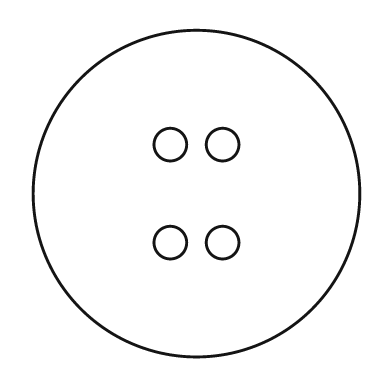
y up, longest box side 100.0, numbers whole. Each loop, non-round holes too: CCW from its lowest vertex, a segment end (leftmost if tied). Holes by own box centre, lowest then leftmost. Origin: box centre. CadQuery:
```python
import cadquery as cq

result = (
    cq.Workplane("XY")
    .moveTo(0.0, 0.0)
    .circle(50.0)
    .moveTo(-8.0, -15.0)
    .circle(5.0)
    .moveTo(8.0, -15.0)
    .circle(5.0)
    .moveTo(-8.0, 15.0)
    .circle(5.0)
    .moveTo(8.0, 15.0)
    .circle(5.0)
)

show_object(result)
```